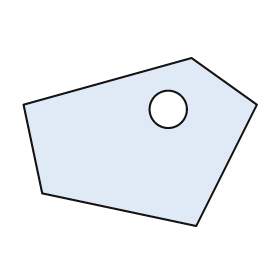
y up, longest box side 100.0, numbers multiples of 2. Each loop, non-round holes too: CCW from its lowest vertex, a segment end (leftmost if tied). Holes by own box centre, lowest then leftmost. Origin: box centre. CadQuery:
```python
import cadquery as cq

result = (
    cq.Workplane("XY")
    .moveTo(24.0, -36.0)
    .lineTo(50.0, 16.0)
    .lineTo(22.0, 36.0)
    .lineTo(-50.0, 16.0)
    .lineTo(-42.0, -22.0)
    .close()
    .moveTo(12.0, 14.0)
    .circle(8.0)
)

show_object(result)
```